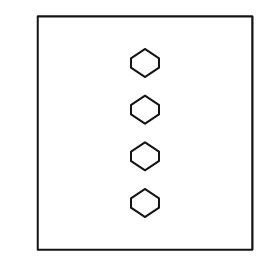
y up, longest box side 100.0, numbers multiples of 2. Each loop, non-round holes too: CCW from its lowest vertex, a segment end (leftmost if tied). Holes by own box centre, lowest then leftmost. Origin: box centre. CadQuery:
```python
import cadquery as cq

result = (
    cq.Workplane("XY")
    .moveTo(-46.0, -50.0)
    .lineTo(46.0, -50.0)
    .lineTo(46.0, 50.0)
    .lineTo(-46.0, 50.0)
    .close()
    .moveTo(0.0, -36.0)
    .lineTo(6.0, -32.0)
    .lineTo(6.0, -28.0)
    .lineTo(0.0, -24.0)
    .lineTo(-6.0, -28.0)
    .lineTo(-6.0, -32.0)
    .close()
    .moveTo(0.0, -16.0)
    .lineTo(6.0, -12.0)
    .lineTo(6.0, -8.0)
    .lineTo(0.0, -4.0)
    .lineTo(-6.0, -8.0)
    .lineTo(-6.0, -12.0)
    .close()
    .moveTo(0.0, 4.0)
    .lineTo(6.0, 8.0)
    .lineTo(6.0, 12.0)
    .lineTo(0.0, 16.0)
    .lineTo(-6.0, 12.0)
    .lineTo(-6.0, 8.0)
    .close()
    .moveTo(0.0, 24.0)
    .lineTo(6.0, 28.0)
    .lineTo(6.0, 32.0)
    .lineTo(0.0, 36.0)
    .lineTo(-6.0, 32.0)
    .lineTo(-6.0, 28.0)
    .close()
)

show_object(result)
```